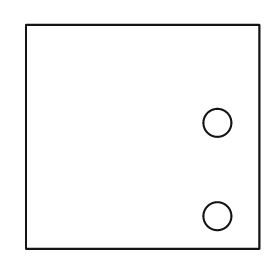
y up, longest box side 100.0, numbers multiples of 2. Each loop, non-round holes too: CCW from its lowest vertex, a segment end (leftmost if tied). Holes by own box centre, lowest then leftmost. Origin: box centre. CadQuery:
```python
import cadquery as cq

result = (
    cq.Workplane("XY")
    .moveTo(-50.0, -48.0)
    .lineTo(50.0, -48.0)
    .lineTo(50.0, 48.0)
    .lineTo(-50.0, 48.0)
    .close()
    .moveTo(32.0, -34.0)
    .circle(6.0)
    .moveTo(32.0, 6.0)
    .circle(6.0)
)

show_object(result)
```